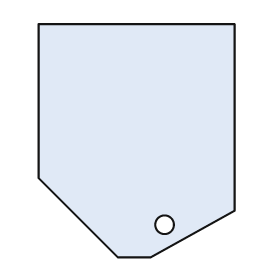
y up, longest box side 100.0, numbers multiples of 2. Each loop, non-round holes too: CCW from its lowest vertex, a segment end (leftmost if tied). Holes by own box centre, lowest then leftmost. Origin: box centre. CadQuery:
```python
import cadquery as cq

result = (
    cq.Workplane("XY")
    .moveTo(-8.0, -50.0)
    .lineTo(6.0, -50.0)
    .lineTo(42.0, -30.0)
    .lineTo(42.0, 50.0)
    .lineTo(-42.0, 50.0)
    .lineTo(-42.0, -16.0)
    .close()
    .moveTo(12.0, -36.0)
    .circle(4.0)
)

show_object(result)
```